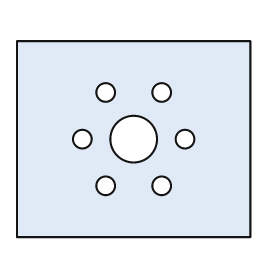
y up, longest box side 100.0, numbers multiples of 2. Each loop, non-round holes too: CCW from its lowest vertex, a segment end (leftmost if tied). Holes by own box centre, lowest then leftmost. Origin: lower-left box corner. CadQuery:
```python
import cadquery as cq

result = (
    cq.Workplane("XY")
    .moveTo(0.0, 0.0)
    .lineTo(100.0, 0.0)
    .lineTo(100.0, 84.0)
    .lineTo(0.0, 84.0)
    .close()
    .moveTo(38.0, 22.0)
    .circle(4.0)
    .moveTo(62.0, 22.0)
    .circle(4.0)
    .moveTo(28.0, 42.0)
    .circle(4.0)
    .moveTo(50.0, 42.0)
    .circle(10.0)
    .moveTo(72.0, 42.0)
    .circle(4.0)
    .moveTo(38.0, 62.0)
    .circle(4.0)
    .moveTo(62.0, 62.0)
    .circle(4.0)
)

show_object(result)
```